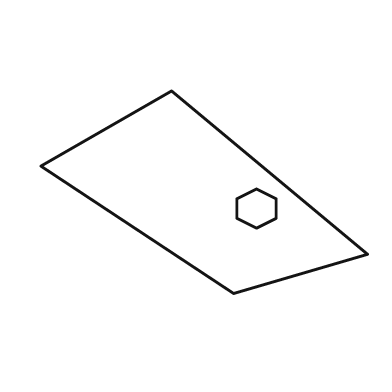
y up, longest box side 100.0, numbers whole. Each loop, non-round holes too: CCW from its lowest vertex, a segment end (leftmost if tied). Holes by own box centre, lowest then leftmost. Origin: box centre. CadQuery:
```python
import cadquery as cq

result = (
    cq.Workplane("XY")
    .moveTo(9.0, -31.0)
    .lineTo(50.0, -19.0)
    .lineTo(-10.0, 31.0)
    .lineTo(-50.0, 8.0)
    .close()
    .moveTo(16.0, -11.0)
    .lineTo(22.0, -8.0)
    .lineTo(22.0, -2.0)
    .lineTo(16.0, 1.0)
    .lineTo(10.0, -2.0)
    .lineTo(10.0, -8.0)
    .close()
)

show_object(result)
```